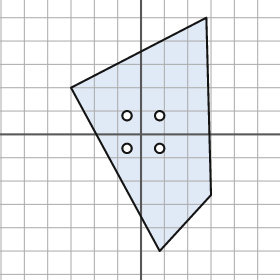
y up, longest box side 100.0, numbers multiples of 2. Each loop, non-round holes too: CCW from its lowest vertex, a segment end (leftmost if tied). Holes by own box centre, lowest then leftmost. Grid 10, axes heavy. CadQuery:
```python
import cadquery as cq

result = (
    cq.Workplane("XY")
    .moveTo(8.0, -50.0)
    .lineTo(30.0, -26.0)
    .lineTo(28.0, 50.0)
    .lineTo(-30.0, 20.0)
    .close()
    .moveTo(-6.0, -6.0)
    .circle(2.0)
    .moveTo(8.0, -6.0)
    .circle(2.0)
    .moveTo(-6.0, 8.0)
    .circle(2.0)
    .moveTo(8.0, 8.0)
    .circle(2.0)
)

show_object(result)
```